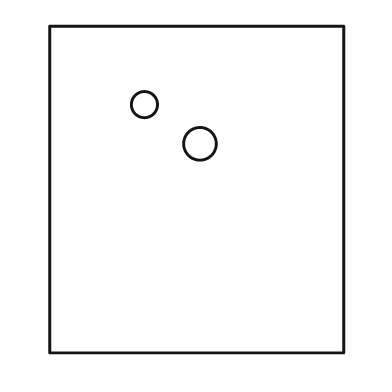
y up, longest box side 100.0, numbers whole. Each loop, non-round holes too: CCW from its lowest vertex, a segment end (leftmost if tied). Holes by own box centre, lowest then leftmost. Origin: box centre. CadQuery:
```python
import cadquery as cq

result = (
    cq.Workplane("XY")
    .moveTo(-45.0, -50.0)
    .lineTo(45.0, -50.0)
    .lineTo(45.0, 50.0)
    .lineTo(-45.0, 50.0)
    .close()
    .moveTo(1.0, 14.0)
    .circle(5.0)
    .moveTo(-16.0, 26.0)
    .circle(4.0)
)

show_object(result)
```